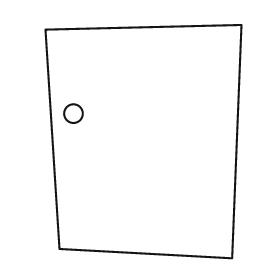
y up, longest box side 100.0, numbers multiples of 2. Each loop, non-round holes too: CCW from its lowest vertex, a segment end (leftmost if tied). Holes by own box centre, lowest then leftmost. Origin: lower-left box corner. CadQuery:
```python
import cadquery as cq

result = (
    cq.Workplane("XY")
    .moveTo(80.0, 0.0)
    .lineTo(84.0, 100.0)
    .lineTo(0.0, 98.0)
    .lineTo(6.0, 4.0)
    .close()
    .moveTo(12.0, 62.0)
    .circle(4.0)
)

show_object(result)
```